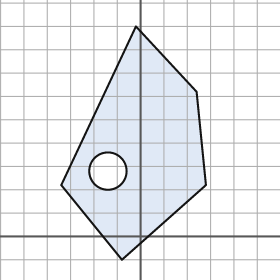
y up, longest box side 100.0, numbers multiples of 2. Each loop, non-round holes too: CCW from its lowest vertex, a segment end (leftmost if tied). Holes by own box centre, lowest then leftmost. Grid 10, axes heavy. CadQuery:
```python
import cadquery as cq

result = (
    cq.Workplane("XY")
    .moveTo(-8.0, -10.0)
    .lineTo(28.0, 22.0)
    .lineTo(24.0, 62.0)
    .lineTo(-2.0, 90.0)
    .lineTo(-34.0, 22.0)
    .close()
    .moveTo(-14.0, 28.0)
    .circle(8.0)
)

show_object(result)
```